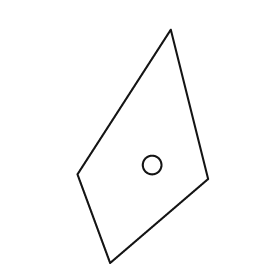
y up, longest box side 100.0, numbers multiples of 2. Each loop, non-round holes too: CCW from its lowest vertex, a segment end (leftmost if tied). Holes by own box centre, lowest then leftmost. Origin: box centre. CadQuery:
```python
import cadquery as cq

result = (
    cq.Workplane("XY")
    .moveTo(-14.0, -50.0)
    .lineTo(28.0, -14.0)
    .lineTo(12.0, 50.0)
    .lineTo(-28.0, -12.0)
    .close()
    .moveTo(4.0, -8.0)
    .circle(4.0)
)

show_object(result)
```